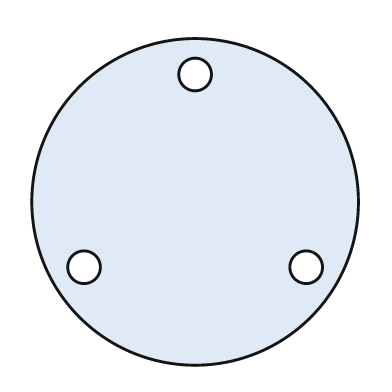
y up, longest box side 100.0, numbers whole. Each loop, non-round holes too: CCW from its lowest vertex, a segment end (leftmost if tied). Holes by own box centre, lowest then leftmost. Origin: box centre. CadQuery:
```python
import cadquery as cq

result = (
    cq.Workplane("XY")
    .moveTo(0.0, 0.0)
    .circle(50.0)
    .moveTo(-34.0, -20.0)
    .circle(5.0)
    .moveTo(34.0, -20.0)
    .circle(5.0)
    .moveTo(0.0, 39.0)
    .circle(5.0)
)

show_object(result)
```